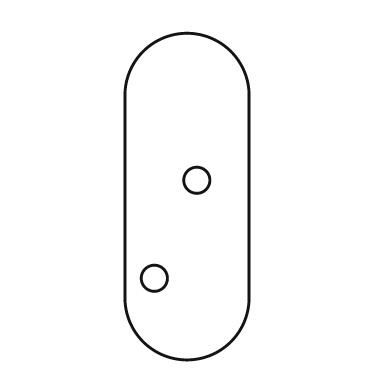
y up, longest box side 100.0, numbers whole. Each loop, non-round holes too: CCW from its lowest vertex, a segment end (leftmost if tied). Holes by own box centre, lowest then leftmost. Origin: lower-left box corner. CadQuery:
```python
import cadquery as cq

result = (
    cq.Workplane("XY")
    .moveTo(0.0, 19.0)
    .threePointArc((19.0, 0.0), (38.0, 19.0))
    .lineTo(38.0, 81.0)
    .threePointArc((19.0, 100.0), (0.0, 81.0))
    .close()
    .moveTo(9.0, 25.0)
    .circle(4.0)
    .moveTo(22.0, 55.0)
    .circle(4.0)
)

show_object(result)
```